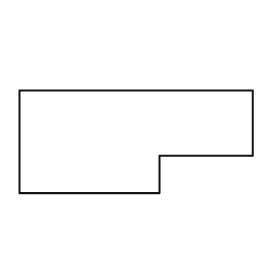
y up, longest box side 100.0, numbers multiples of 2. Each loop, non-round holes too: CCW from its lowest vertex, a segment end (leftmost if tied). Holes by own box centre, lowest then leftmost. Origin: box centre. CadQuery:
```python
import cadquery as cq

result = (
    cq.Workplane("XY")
    .moveTo(-50.0, -22.0)
    .lineTo(10.0, -22.0)
    .lineTo(10.0, -6.0)
    .lineTo(50.0, -6.0)
    .lineTo(50.0, 22.0)
    .lineTo(-50.0, 22.0)
    .close()
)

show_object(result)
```